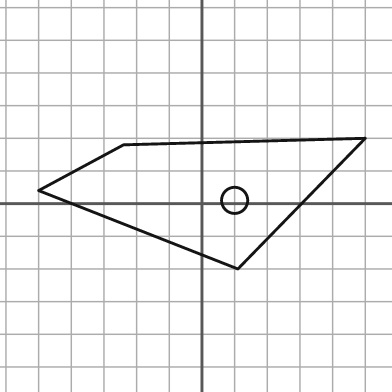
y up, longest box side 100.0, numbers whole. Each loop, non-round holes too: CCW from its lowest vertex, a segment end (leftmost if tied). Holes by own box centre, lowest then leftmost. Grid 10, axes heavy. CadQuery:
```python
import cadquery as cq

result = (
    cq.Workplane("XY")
    .moveTo(11.0, -20.0)
    .lineTo(50.0, 20.0)
    .lineTo(-24.0, 18.0)
    .lineTo(-50.0, 4.0)
    .close()
    .moveTo(10.0, 1.0)
    .circle(4.0)
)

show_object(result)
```